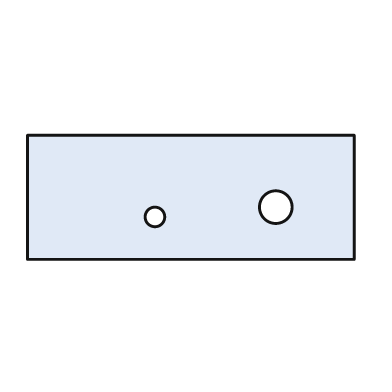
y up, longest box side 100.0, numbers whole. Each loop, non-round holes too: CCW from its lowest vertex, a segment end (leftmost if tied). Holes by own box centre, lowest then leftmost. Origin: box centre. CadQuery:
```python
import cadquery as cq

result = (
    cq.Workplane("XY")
    .moveTo(-50.0, -19.0)
    .lineTo(50.0, -19.0)
    .lineTo(50.0, 19.0)
    .lineTo(-50.0, 19.0)
    .close()
    .moveTo(-11.0, -6.0)
    .circle(3.0)
    .moveTo(26.0, -3.0)
    .circle(5.0)
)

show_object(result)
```